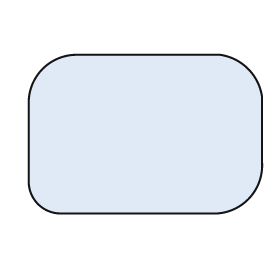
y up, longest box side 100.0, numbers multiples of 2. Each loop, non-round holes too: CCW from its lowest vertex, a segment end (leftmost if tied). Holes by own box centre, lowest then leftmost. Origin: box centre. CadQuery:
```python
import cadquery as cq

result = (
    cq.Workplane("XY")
    .moveTo(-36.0, -34.0)
    .lineTo(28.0, -34.0)
    .threePointArc((44.0, -28.0), (50.0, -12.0))
    .lineTo(50.0, 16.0)
    .threePointArc((44.0, 28.0), (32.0, 34.0))
    .lineTo(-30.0, 34.0)
    .threePointArc((-44.0, 28.0), (-50.0, 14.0))
    .lineTo(-50.0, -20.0)
    .threePointArc((-46.0, -30.0), (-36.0, -34.0))
    .close()
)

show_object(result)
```